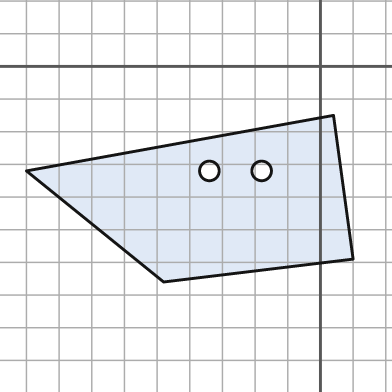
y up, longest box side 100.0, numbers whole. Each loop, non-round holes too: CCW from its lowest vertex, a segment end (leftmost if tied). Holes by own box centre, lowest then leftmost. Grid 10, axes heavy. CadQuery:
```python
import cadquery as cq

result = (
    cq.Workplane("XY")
    .moveTo(-48.0, -66.0)
    .lineTo(10.0, -59.0)
    .lineTo(4.0, -15.0)
    .lineTo(-90.0, -32.0)
    .close()
    .moveTo(-34.0, -32.0)
    .circle(3.0)
    .moveTo(-18.0, -32.0)
    .circle(3.0)
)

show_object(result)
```